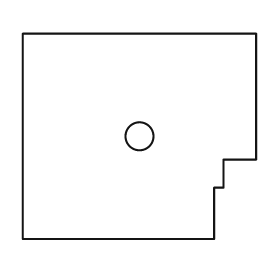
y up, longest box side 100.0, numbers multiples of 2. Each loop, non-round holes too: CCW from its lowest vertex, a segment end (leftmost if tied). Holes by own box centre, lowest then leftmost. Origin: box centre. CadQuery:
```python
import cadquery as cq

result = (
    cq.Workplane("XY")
    .moveTo(-50.0, -44.0)
    .lineTo(32.0, -44.0)
    .lineTo(32.0, -22.0)
    .lineTo(36.0, -22.0)
    .lineTo(36.0, -10.0)
    .lineTo(50.0, -10.0)
    .lineTo(50.0, 44.0)
    .lineTo(-50.0, 44.0)
    .close()
    .moveTo(0.0, 0.0)
    .circle(6.0)
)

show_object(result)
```